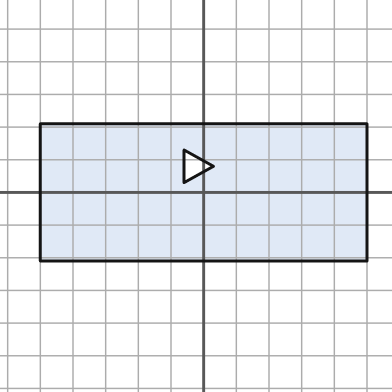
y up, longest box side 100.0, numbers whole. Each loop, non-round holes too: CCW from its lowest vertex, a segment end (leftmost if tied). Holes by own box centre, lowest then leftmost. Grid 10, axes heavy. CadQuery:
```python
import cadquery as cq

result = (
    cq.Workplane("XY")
    .moveTo(-50.0, -21.0)
    .lineTo(50.0, -21.0)
    .lineTo(50.0, 21.0)
    .lineTo(-50.0, 21.0)
    .close()
    .moveTo(-6.0, 3.0)
    .lineTo(3.0, 8.0)
    .lineTo(-6.0, 13.0)
    .close()
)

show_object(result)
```